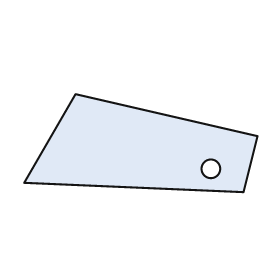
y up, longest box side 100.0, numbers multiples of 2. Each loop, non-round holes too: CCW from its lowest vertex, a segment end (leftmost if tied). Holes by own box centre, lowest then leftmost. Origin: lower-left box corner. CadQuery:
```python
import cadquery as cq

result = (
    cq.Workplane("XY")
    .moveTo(94.0, 0.0)
    .lineTo(100.0, 24.0)
    .lineTo(22.0, 42.0)
    .lineTo(0.0, 4.0)
    .close()
    .moveTo(80.0, 10.0)
    .circle(4.0)
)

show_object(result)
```